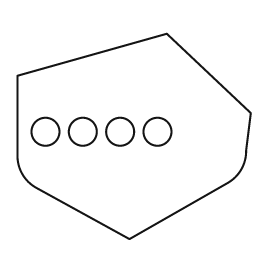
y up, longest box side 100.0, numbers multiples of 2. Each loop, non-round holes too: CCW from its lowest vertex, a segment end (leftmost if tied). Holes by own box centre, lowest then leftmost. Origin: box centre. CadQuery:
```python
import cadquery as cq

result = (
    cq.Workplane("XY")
    .moveTo(-2.0, -44.0)
    .lineTo(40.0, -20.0)
    .threePointArc((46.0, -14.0), (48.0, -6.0))
    .lineTo(50.0, 10.0)
    .lineTo(14.0, 44.0)
    .lineTo(-50.0, 26.0)
    .lineTo(-50.0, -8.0)
    .threePointArc((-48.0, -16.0), (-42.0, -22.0))
    .close()
    .moveTo(-38.0, 2.0)
    .circle(6.0)
    .moveTo(-22.0, 2.0)
    .circle(6.0)
    .moveTo(-6.0, 2.0)
    .circle(6.0)
    .moveTo(10.0, 2.0)
    .circle(6.0)
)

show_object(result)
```